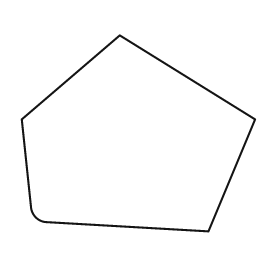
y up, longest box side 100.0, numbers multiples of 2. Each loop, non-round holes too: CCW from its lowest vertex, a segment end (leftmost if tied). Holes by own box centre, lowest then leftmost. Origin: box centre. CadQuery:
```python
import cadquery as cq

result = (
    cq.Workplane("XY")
    .moveTo(30.0, -42.0)
    .lineTo(50.0, 6.0)
    .lineTo(-8.0, 42.0)
    .lineTo(-50.0, 6.0)
    .lineTo(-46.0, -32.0)
    .threePointArc((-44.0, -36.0), (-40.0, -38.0))
    .close()
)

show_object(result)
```